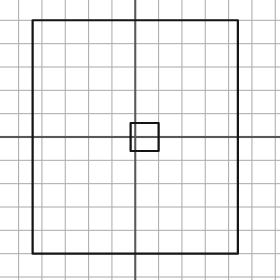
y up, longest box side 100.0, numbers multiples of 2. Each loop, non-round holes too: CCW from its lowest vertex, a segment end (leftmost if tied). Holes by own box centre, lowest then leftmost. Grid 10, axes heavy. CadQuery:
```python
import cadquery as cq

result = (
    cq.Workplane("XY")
    .moveTo(-44.0, -50.0)
    .lineTo(44.0, -50.0)
    .lineTo(44.0, 50.0)
    .lineTo(-44.0, 50.0)
    .close()
    .moveTo(-2.0, -6.0)
    .lineTo(10.0, -6.0)
    .lineTo(10.0, 6.0)
    .lineTo(-2.0, 6.0)
    .close()
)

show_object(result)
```